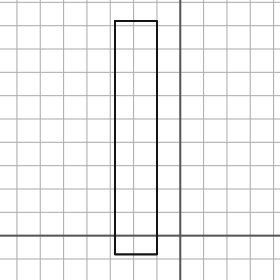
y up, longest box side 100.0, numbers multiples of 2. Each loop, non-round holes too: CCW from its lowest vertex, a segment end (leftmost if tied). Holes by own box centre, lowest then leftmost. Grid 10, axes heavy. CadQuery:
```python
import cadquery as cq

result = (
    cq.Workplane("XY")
    .moveTo(-28.0, -8.0)
    .lineTo(-10.0, -8.0)
    .lineTo(-10.0, 92.0)
    .lineTo(-28.0, 92.0)
    .close()
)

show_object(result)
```